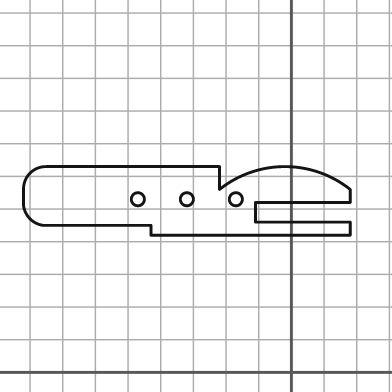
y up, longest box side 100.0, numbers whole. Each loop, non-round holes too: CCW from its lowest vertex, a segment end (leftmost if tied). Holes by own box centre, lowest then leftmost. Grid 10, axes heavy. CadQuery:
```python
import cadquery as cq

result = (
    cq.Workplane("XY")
    .moveTo(-43.0, 42.0)
    .lineTo(18.0, 42.0)
    .lineTo(18.0, 46.0)
    .lineTo(-11.0, 46.0)
    .lineTo(-11.0, 52.0)
    .lineTo(18.0, 52.0)
    .lineTo(18.0, 56.0)
    .threePointArc((-2.0, 63.0), (-22.0, 56.0))
    .lineTo(-22.0, 63.0)
    .lineTo(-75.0, 63.0)
    .threePointArc((-80.0, 61.0), (-82.0, 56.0))
    .lineTo(-82.0, 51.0)
    .threePointArc((-80.0, 47.0), (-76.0, 45.0))
    .lineTo(-43.0, 45.0)
    .close()
    .moveTo(-47.0, 53.0)
    .circle(2.0)
    .moveTo(-32.0, 53.0)
    .circle(2.0)
    .moveTo(-17.0, 53.0)
    .circle(2.0)
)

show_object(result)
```